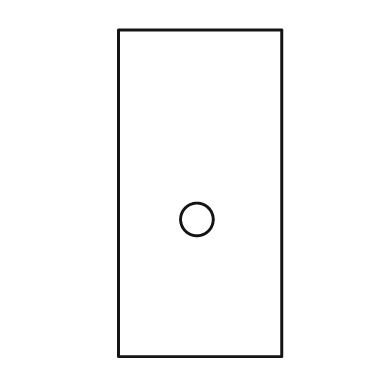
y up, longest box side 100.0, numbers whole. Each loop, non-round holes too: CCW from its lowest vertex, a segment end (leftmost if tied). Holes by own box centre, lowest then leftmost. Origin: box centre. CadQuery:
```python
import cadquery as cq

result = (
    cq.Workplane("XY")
    .moveTo(-25.0, -50.0)
    .lineTo(25.0, -50.0)
    .lineTo(25.0, 50.0)
    .lineTo(-25.0, 50.0)
    .close()
    .moveTo(-1.0, -8.0)
    .circle(5.0)
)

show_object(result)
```